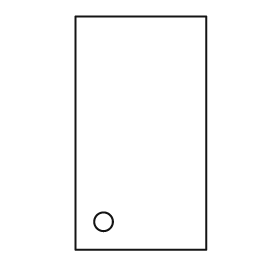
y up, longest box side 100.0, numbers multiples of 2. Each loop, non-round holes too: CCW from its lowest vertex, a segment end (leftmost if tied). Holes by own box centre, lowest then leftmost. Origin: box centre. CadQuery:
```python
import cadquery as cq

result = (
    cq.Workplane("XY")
    .moveTo(-28.0, -50.0)
    .lineTo(28.0, -50.0)
    .lineTo(28.0, 50.0)
    .lineTo(-28.0, 50.0)
    .close()
    .moveTo(-16.0, -38.0)
    .circle(4.0)
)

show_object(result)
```